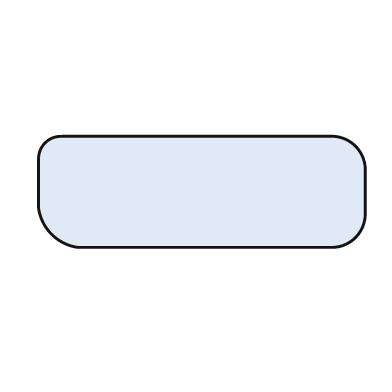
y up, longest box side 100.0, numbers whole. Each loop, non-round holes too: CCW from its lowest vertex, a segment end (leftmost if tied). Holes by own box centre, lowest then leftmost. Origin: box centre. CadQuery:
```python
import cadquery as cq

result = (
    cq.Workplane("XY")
    .moveTo(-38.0, -17.0)
    .lineTo(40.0, -17.0)
    .threePointArc((47.0, -14.0), (50.0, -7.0))
    .lineTo(50.0, 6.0)
    .threePointArc((47.0, 14.0), (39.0, 17.0))
    .lineTo(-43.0, 17.0)
    .threePointArc((-48.0, 15.0), (-50.0, 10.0))
    .lineTo(-50.0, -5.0)
    .threePointArc((-46.0, -13.0), (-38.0, -17.0))
    .close()
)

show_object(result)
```